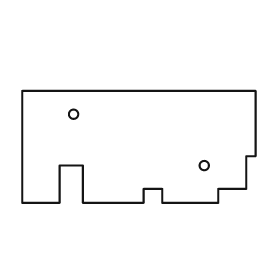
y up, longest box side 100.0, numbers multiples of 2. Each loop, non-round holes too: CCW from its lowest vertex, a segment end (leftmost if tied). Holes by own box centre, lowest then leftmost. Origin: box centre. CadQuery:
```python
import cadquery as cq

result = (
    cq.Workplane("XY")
    .moveTo(-50.0, -24.0)
    .lineTo(-34.0, -24.0)
    .lineTo(-34.0, -8.0)
    .lineTo(-24.0, -8.0)
    .lineTo(-24.0, -24.0)
    .lineTo(2.0, -24.0)
    .lineTo(2.0, -18.0)
    .lineTo(10.0, -18.0)
    .lineTo(10.0, -24.0)
    .lineTo(34.0, -24.0)
    .lineTo(34.0, -18.0)
    .lineTo(46.0, -18.0)
    .lineTo(46.0, -4.0)
    .lineTo(50.0, -4.0)
    .lineTo(50.0, 24.0)
    .lineTo(-50.0, 24.0)
    .close()
    .moveTo(28.0, -8.0)
    .circle(2.0)
    .moveTo(-28.0, 14.0)
    .circle(2.0)
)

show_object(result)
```